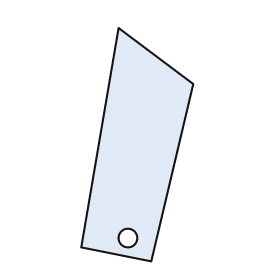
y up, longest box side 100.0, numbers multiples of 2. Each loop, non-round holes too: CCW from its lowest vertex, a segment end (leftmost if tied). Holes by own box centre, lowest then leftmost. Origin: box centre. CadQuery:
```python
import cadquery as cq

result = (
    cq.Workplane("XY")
    .moveTo(6.0, -50.0)
    .lineTo(24.0, 26.0)
    .lineTo(-8.0, 50.0)
    .lineTo(-24.0, -44.0)
    .close()
    .moveTo(-4.0, -40.0)
    .circle(4.0)
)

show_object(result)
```